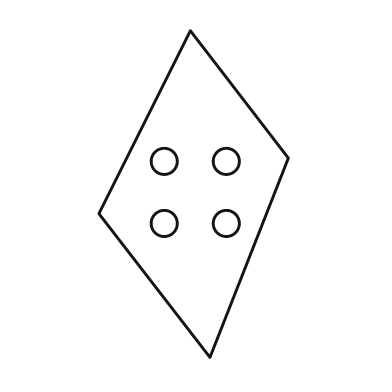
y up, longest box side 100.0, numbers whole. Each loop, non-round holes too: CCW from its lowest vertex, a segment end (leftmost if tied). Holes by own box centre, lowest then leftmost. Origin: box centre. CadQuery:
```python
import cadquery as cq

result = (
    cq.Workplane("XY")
    .moveTo(5.0, -50.0)
    .lineTo(29.0, 11.0)
    .lineTo(-1.0, 50.0)
    .lineTo(-29.0, -6.0)
    .close()
    .moveTo(-9.0, -9.0)
    .circle(4.0)
    .moveTo(10.0, -9.0)
    .circle(4.0)
    .moveTo(-9.0, 10.0)
    .circle(4.0)
    .moveTo(10.0, 10.0)
    .circle(4.0)
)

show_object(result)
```